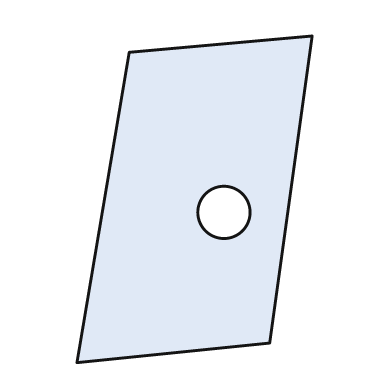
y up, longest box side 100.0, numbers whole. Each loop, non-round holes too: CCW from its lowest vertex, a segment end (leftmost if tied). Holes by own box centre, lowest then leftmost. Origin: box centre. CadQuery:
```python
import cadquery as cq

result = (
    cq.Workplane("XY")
    .moveTo(-36.0, -50.0)
    .lineTo(23.0, -44.0)
    .lineTo(36.0, 50.0)
    .lineTo(-20.0, 45.0)
    .close()
    .moveTo(9.0, -4.0)
    .circle(8.0)
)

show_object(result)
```